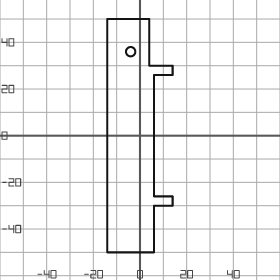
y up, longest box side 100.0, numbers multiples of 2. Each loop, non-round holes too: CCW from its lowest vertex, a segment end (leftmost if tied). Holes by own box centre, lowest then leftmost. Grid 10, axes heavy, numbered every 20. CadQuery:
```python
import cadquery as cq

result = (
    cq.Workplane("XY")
    .moveTo(-14.0, -50.0)
    .lineTo(6.0, -50.0)
    .lineTo(6.0, -30.0)
    .lineTo(14.0, -30.0)
    .lineTo(14.0, -26.0)
    .lineTo(6.0, -26.0)
    .lineTo(6.0, 26.0)
    .lineTo(14.0, 26.0)
    .lineTo(14.0, 30.0)
    .lineTo(4.0, 30.0)
    .lineTo(4.0, 50.0)
    .lineTo(-14.0, 50.0)
    .close()
    .moveTo(-4.0, 36.0)
    .circle(2.0)
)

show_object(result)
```